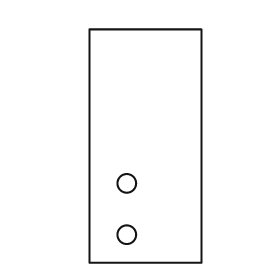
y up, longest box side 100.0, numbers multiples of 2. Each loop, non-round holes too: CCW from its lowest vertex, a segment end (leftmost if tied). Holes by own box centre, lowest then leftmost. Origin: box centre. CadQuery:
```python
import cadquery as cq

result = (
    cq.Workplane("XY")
    .moveTo(-24.0, -50.0)
    .lineTo(24.0, -50.0)
    .lineTo(24.0, 50.0)
    .lineTo(-24.0, 50.0)
    .close()
    .moveTo(-8.0, -38.0)
    .circle(4.0)
    .moveTo(-8.0, -16.0)
    .circle(4.0)
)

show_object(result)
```